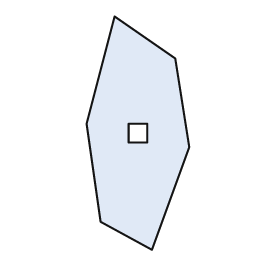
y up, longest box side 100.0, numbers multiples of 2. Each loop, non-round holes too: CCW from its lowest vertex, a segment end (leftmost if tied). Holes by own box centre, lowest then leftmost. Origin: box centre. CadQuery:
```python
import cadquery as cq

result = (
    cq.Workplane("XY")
    .moveTo(6.0, -50.0)
    .lineTo(22.0, -6.0)
    .lineTo(16.0, 32.0)
    .lineTo(-10.0, 50.0)
    .lineTo(-22.0, 4.0)
    .lineTo(-16.0, -38.0)
    .close()
    .moveTo(-4.0, -4.0)
    .lineTo(4.0, -4.0)
    .lineTo(4.0, 4.0)
    .lineTo(-4.0, 4.0)
    .close()
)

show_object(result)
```